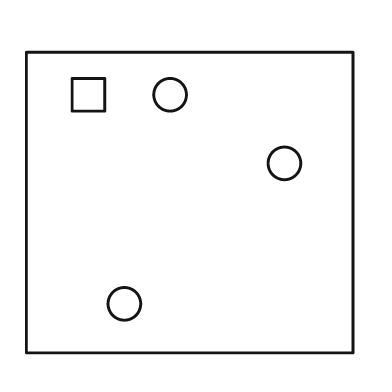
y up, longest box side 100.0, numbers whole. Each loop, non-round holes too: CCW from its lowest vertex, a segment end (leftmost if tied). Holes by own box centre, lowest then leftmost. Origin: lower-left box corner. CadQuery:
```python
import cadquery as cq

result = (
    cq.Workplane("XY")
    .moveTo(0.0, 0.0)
    .lineTo(100.0, 0.0)
    .lineTo(100.0, 92.0)
    .lineTo(0.0, 92.0)
    .close()
    .moveTo(30.0, 15.0)
    .circle(5.0)
    .moveTo(79.0, 58.0)
    .circle(5.0)
    .moveTo(14.0, 74.0)
    .lineTo(24.0, 74.0)
    .lineTo(24.0, 84.0)
    .lineTo(14.0, 84.0)
    .close()
    .moveTo(44.0, 79.0)
    .circle(5.0)
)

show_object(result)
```